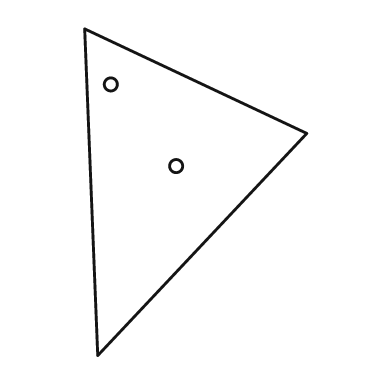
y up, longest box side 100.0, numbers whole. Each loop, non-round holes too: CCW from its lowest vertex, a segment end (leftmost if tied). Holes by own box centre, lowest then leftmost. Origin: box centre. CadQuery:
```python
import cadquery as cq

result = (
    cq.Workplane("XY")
    .moveTo(-30.0, -50.0)
    .lineTo(34.0, 18.0)
    .lineTo(-34.0, 50.0)
    .close()
    .moveTo(-6.0, 8.0)
    .circle(2.0)
    .moveTo(-26.0, 33.0)
    .circle(2.0)
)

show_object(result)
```